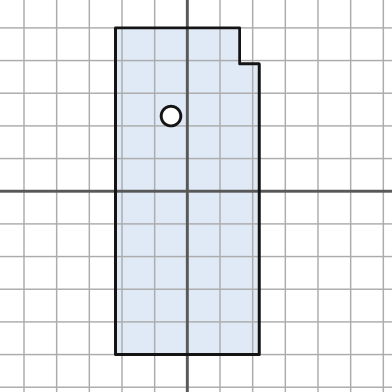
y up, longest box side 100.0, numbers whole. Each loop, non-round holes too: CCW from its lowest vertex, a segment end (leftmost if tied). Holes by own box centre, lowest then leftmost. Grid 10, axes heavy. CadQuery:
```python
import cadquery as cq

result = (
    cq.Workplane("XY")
    .moveTo(-22.0, -50.0)
    .lineTo(22.0, -50.0)
    .lineTo(22.0, 39.0)
    .lineTo(16.0, 39.0)
    .lineTo(16.0, 50.0)
    .lineTo(-22.0, 50.0)
    .close()
    .moveTo(-5.0, 23.0)
    .circle(3.0)
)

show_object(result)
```